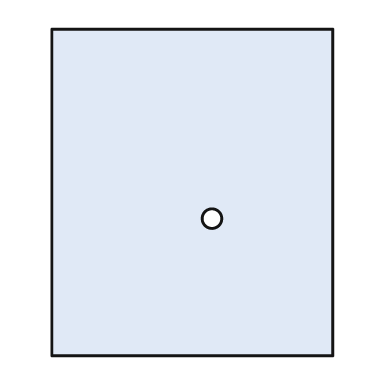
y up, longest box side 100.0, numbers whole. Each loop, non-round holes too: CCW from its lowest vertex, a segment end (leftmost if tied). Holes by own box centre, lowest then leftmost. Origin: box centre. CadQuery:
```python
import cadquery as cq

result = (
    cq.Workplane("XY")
    .moveTo(-43.0, -50.0)
    .lineTo(43.0, -50.0)
    .lineTo(43.0, 50.0)
    .lineTo(-43.0, 50.0)
    .close()
    .moveTo(6.0, -8.0)
    .circle(3.0)
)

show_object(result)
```